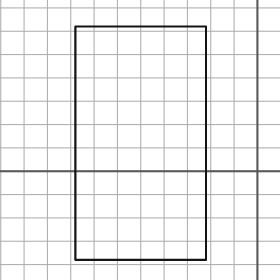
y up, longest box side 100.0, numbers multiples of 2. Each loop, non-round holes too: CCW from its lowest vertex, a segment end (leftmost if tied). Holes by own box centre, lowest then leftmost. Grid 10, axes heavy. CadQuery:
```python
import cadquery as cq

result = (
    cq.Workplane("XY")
    .moveTo(-78.0, -38.0)
    .lineTo(-22.0, -38.0)
    .lineTo(-22.0, 62.0)
    .lineTo(-78.0, 62.0)
    .close()
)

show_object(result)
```